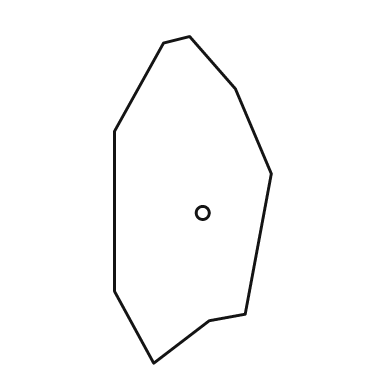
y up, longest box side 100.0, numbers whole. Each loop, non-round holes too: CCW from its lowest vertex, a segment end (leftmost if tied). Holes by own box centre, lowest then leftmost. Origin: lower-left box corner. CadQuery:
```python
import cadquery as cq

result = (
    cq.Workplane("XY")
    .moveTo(12.0, 0.0)
    .lineTo(29.0, 13.0)
    .lineTo(40.0, 15.0)
    .lineTo(48.0, 58.0)
    .lineTo(37.0, 84.0)
    .lineTo(23.0, 100.0)
    .lineTo(15.0, 98.0)
    .lineTo(0.0, 71.0)
    .lineTo(0.0, 22.0)
    .close()
    .moveTo(27.0, 46.0)
    .circle(2.0)
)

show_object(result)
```